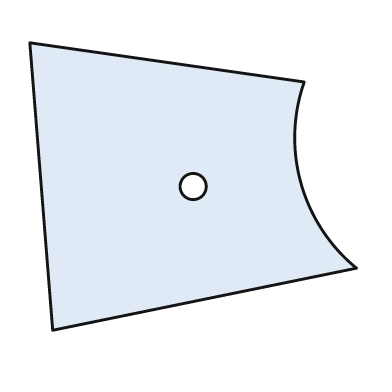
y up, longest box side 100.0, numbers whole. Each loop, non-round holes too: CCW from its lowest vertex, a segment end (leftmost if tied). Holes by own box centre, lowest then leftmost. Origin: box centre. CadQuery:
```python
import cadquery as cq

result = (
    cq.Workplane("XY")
    .moveTo(-43.0, -44.0)
    .lineTo(50.0, -25.0)
    .threePointArc((33.0, 1.0), (34.0, 32.0))
    .lineTo(-50.0, 44.0)
    .close()
    .moveTo(0.0, 0.0)
    .circle(4.0)
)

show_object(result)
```